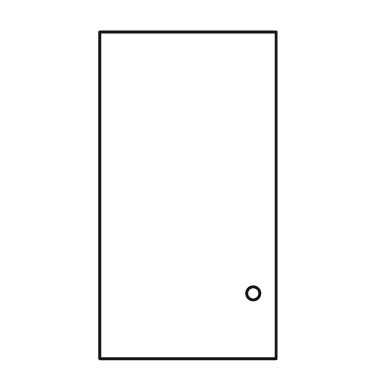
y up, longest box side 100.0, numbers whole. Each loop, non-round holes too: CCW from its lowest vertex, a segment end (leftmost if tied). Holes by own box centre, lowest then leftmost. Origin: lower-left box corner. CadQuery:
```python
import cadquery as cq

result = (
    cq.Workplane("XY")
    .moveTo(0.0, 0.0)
    .lineTo(54.0, 0.0)
    .lineTo(54.0, 100.0)
    .lineTo(0.0, 100.0)
    .close()
    .moveTo(47.0, 20.0)
    .circle(2.0)
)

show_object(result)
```